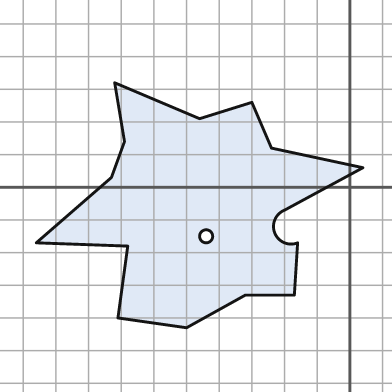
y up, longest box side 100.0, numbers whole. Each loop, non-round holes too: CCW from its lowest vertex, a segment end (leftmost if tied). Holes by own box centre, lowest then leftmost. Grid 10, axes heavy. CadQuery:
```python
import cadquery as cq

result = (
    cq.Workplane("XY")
    .moveTo(-50.0, -43.0)
    .lineTo(-32.0, -33.0)
    .lineTo(-17.0, -33.0)
    .lineTo(-16.0, -17.0)
    .threePointArc((-23.0, -14.0), (-20.0, -7.0))
    .lineTo(4.0, 6.0)
    .lineTo(-24.0, 12.0)
    .lineTo(-30.0, 26.0)
    .lineTo(-46.0, 21.0)
    .lineTo(-72.0, 32.0)
    .lineTo(-69.0, 14.0)
    .lineTo(-73.0, 3.0)
    .lineTo(-96.0, -17.0)
    .lineTo(-68.0, -18.0)
    .lineTo(-71.0, -40.0)
    .close()
    .moveTo(-44.0, -15.0)
    .circle(2.0)
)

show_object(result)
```